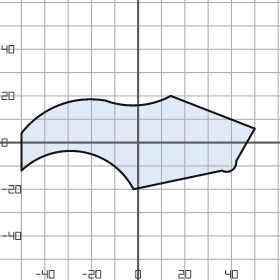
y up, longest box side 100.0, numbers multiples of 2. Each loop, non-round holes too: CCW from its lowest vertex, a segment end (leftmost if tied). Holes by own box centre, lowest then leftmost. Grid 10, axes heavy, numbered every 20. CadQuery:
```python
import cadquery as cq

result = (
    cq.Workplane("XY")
    .moveTo(-2.0, -20.0)
    .lineTo(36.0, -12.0)
    .threePointArc((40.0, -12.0), (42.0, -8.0))
    .lineTo(50.0, 6.0)
    .lineTo(14.0, 20.0)
    .threePointArc((0.0, 16.0), (-14.0, 18.0))
    .threePointArc((-34.0, 16.0), (-50.0, 4.0))
    .lineTo(-50.0, -12.0)
    .threePointArc((-24.0, -4.0), (-2.0, -20.0))
    .close()
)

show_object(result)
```